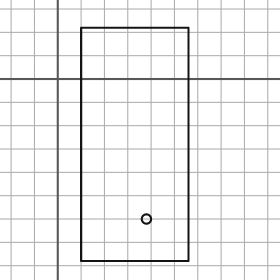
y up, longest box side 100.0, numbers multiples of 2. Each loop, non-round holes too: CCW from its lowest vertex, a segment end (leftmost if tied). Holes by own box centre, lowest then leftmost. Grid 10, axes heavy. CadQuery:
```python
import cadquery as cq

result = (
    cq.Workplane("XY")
    .moveTo(10.0, -78.0)
    .lineTo(56.0, -78.0)
    .lineTo(56.0, 22.0)
    .lineTo(10.0, 22.0)
    .close()
    .moveTo(38.0, -60.0)
    .circle(2.0)
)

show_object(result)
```